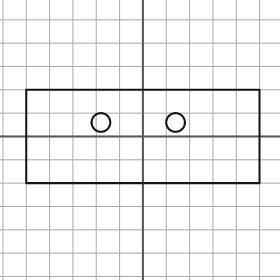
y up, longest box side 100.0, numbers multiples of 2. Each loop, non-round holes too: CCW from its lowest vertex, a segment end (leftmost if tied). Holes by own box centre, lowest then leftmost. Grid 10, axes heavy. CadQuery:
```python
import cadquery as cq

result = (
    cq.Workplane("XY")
    .moveTo(-50.0, -20.0)
    .lineTo(50.0, -20.0)
    .lineTo(50.0, 20.0)
    .lineTo(-50.0, 20.0)
    .close()
    .moveTo(-18.0, 6.0)
    .circle(4.0)
    .moveTo(14.0, 6.0)
    .circle(4.0)
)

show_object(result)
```